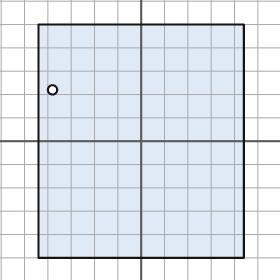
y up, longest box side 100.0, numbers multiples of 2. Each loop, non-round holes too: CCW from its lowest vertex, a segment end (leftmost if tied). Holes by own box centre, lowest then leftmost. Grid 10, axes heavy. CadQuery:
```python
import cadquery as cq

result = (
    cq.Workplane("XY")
    .moveTo(-44.0, -50.0)
    .lineTo(44.0, -50.0)
    .lineTo(44.0, 50.0)
    .lineTo(-44.0, 50.0)
    .close()
    .moveTo(-38.0, 22.0)
    .circle(2.0)
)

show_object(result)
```